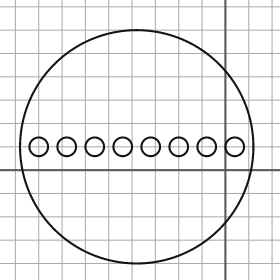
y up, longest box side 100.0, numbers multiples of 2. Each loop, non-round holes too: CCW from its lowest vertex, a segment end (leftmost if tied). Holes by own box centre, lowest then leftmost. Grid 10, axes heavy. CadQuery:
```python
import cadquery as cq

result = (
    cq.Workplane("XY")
    .moveTo(-38.0, 10.0)
    .circle(50.0)
    .moveTo(-80.0, 10.0)
    .circle(4.0)
    .moveTo(-68.0, 10.0)
    .circle(4.0)
    .moveTo(-56.0, 10.0)
    .circle(4.0)
    .moveTo(-44.0, 10.0)
    .circle(4.0)
    .moveTo(-32.0, 10.0)
    .circle(4.0)
    .moveTo(-20.0, 10.0)
    .circle(4.0)
    .moveTo(-8.0, 10.0)
    .circle(4.0)
    .moveTo(4.0, 10.0)
    .circle(4.0)
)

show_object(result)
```